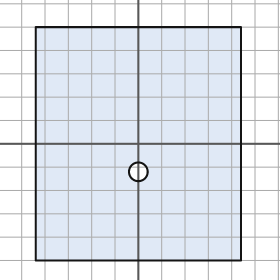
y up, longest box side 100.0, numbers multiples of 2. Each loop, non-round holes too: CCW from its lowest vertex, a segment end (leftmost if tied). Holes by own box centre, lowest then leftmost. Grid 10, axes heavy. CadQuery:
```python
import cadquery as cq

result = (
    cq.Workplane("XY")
    .moveTo(-44.0, -50.0)
    .lineTo(44.0, -50.0)
    .lineTo(44.0, 50.0)
    .lineTo(-44.0, 50.0)
    .close()
    .moveTo(0.0, -12.0)
    .circle(4.0)
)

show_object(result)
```